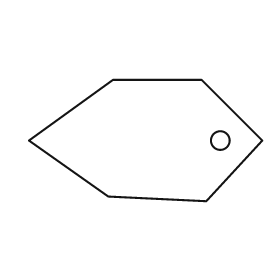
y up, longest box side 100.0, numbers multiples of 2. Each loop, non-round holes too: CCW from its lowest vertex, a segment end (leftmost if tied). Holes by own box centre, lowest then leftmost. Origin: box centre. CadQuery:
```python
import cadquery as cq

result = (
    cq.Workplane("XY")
    .moveTo(26.0, -26.0)
    .lineTo(50.0, 0.0)
    .lineTo(24.0, 26.0)
    .lineTo(-14.0, 26.0)
    .lineTo(-50.0, 0.0)
    .lineTo(-16.0, -24.0)
    .close()
    .moveTo(32.0, 0.0)
    .circle(4.0)
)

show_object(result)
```